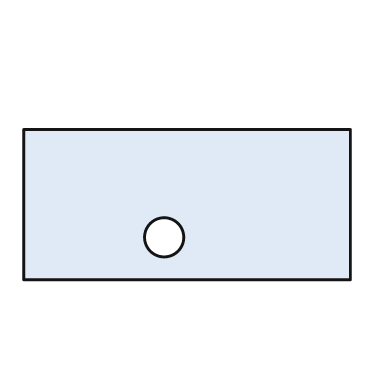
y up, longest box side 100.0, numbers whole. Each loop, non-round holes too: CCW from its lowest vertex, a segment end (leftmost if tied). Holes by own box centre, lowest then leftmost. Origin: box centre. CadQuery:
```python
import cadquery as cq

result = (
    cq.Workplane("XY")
    .moveTo(-50.0, -23.0)
    .lineTo(50.0, -23.0)
    .lineTo(50.0, 23.0)
    .lineTo(-50.0, 23.0)
    .close()
    .moveTo(-7.0, -10.0)
    .circle(6.0)
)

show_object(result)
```